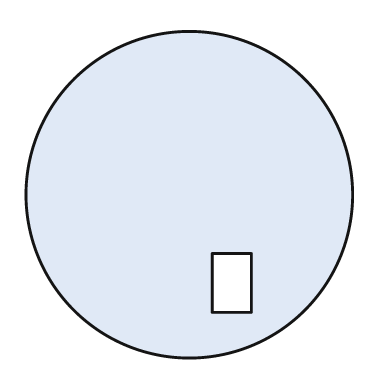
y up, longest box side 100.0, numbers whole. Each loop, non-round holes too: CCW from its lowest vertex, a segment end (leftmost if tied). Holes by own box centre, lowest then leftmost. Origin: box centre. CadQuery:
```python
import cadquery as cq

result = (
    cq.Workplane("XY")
    .moveTo(0.0, 0.0)
    .circle(50.0)
    .moveTo(7.0, -36.0)
    .lineTo(19.0, -36.0)
    .lineTo(19.0, -18.0)
    .lineTo(7.0, -18.0)
    .close()
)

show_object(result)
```